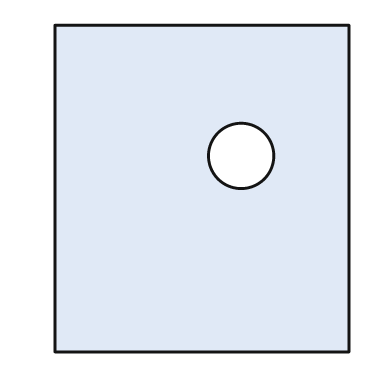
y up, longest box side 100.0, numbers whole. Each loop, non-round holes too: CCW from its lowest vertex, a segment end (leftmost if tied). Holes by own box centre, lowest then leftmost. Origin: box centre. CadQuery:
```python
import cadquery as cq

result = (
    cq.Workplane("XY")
    .moveTo(-45.0, -50.0)
    .lineTo(45.0, -50.0)
    .lineTo(45.0, 50.0)
    .lineTo(-45.0, 50.0)
    .close()
    .moveTo(12.0, 10.0)
    .circle(10.0)
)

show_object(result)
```